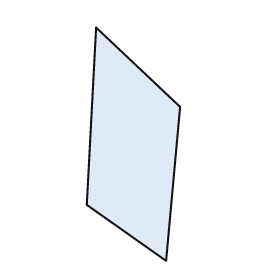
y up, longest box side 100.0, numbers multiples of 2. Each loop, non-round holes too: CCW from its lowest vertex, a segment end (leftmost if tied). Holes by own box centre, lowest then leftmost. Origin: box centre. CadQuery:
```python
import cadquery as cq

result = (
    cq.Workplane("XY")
    .moveTo(14.0, -50.0)
    .lineTo(20.0, 16.0)
    .lineTo(-16.0, 50.0)
    .lineTo(-20.0, -26.0)
    .close()
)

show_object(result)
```